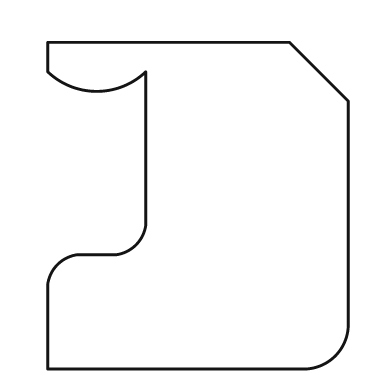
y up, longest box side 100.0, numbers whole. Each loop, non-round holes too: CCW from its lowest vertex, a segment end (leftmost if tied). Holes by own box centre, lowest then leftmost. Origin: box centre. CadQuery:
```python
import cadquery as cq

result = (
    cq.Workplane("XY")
    .moveTo(-46.0, -50.0)
    .lineTo(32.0, -50.0)
    .threePointArc((42.0, -46.0), (46.0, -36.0))
    .lineTo(46.0, 32.0)
    .lineTo(28.0, 50.0)
    .lineTo(-46.0, 50.0)
    .lineTo(-46.0, 41.0)
    .threePointArc((-31.0, 35.0), (-16.0, 41.0))
    .lineTo(-16.0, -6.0)
    .threePointArc((-19.0, -12.0), (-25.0, -15.0))
    .lineTo(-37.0, -15.0)
    .threePointArc((-43.0, -18.0), (-46.0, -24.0))
    .close()
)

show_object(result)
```